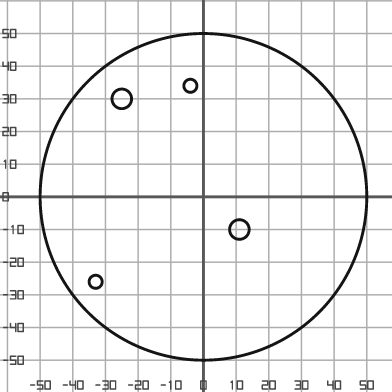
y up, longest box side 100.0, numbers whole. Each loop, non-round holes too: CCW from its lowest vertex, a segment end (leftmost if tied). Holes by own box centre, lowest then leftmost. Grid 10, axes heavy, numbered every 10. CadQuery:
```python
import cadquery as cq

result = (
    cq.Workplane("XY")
    .moveTo(0.0, 0.0)
    .circle(50.0)
    .moveTo(-33.0, -26.0)
    .circle(2.0)
    .moveTo(11.0, -10.0)
    .circle(3.0)
    .moveTo(-25.0, 30.0)
    .circle(3.0)
    .moveTo(-4.0, 34.0)
    .circle(2.0)
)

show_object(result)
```